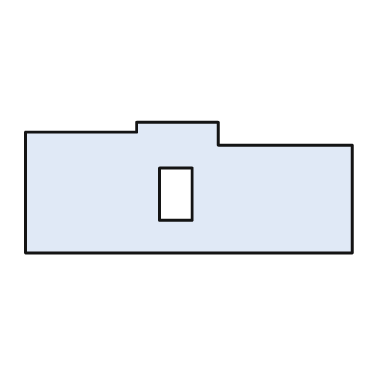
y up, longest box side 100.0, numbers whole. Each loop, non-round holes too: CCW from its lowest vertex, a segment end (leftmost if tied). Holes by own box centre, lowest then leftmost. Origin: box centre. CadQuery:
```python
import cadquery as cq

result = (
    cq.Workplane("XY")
    .moveTo(-50.0, -20.0)
    .lineTo(50.0, -20.0)
    .lineTo(50.0, 13.0)
    .lineTo(9.0, 13.0)
    .lineTo(9.0, 20.0)
    .lineTo(-16.0, 20.0)
    .lineTo(-16.0, 17.0)
    .lineTo(-50.0, 17.0)
    .close()
    .moveTo(-9.0, -10.0)
    .lineTo(1.0, -10.0)
    .lineTo(1.0, 6.0)
    .lineTo(-9.0, 6.0)
    .close()
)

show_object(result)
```